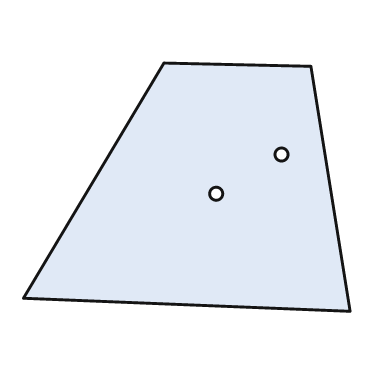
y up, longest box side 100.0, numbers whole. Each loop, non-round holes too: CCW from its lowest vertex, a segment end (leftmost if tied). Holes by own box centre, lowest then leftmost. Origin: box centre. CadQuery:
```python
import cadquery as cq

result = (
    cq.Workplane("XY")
    .moveTo(50.0, -38.0)
    .lineTo(38.0, 37.0)
    .lineTo(-7.0, 38.0)
    .lineTo(-50.0, -34.0)
    .close()
    .moveTo(9.0, -2.0)
    .circle(2.0)
    .moveTo(29.0, 10.0)
    .circle(2.0)
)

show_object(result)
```